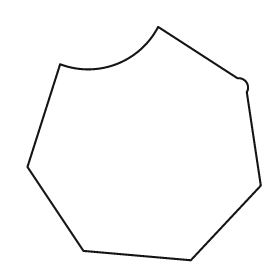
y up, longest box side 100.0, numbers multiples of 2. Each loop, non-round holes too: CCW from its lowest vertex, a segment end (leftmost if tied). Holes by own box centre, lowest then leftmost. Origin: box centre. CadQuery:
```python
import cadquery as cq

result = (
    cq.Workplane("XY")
    .moveTo(20.0, -50.0)
    .lineTo(50.0, -18.0)
    .lineTo(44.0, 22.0)
    .threePointArc((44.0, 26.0), (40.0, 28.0))
    .lineTo(6.0, 50.0)
    .threePointArc((-12.0, 34.0), (-36.0, 34.0))
    .lineTo(-50.0, -10.0)
    .lineTo(-26.0, -46.0)
    .close()
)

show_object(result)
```